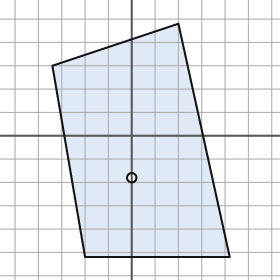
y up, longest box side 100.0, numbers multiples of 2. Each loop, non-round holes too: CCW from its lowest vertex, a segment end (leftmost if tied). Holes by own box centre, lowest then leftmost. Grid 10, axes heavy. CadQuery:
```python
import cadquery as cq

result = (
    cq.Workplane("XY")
    .moveTo(-20.0, -52.0)
    .lineTo(42.0, -52.0)
    .lineTo(20.0, 48.0)
    .lineTo(-34.0, 30.0)
    .close()
    .moveTo(0.0, -18.0)
    .circle(2.0)
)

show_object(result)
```